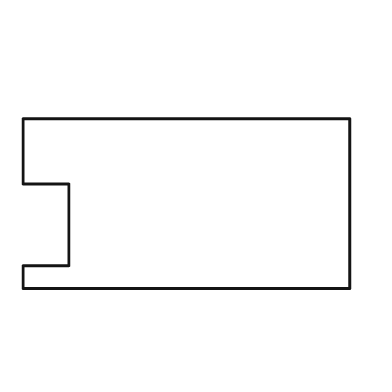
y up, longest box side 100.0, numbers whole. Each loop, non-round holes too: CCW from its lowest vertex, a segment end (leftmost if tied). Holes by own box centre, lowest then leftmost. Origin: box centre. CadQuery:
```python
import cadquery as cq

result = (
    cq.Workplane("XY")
    .moveTo(-50.0, -26.0)
    .lineTo(50.0, -26.0)
    .lineTo(50.0, 26.0)
    .lineTo(-50.0, 26.0)
    .lineTo(-50.0, 6.0)
    .lineTo(-36.0, 6.0)
    .lineTo(-36.0, -19.0)
    .lineTo(-50.0, -19.0)
    .close()
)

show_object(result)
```